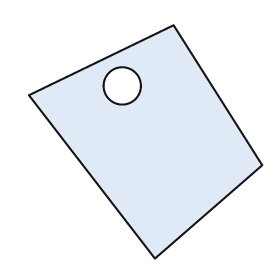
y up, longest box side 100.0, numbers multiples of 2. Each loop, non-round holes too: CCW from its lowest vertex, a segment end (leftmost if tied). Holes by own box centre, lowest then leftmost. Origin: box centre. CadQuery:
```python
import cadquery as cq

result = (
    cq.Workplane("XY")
    .moveTo(4.0, -50.0)
    .lineTo(50.0, -10.0)
    .lineTo(12.0, 50.0)
    .lineTo(-50.0, 20.0)
    .close()
    .moveTo(-10.0, 24.0)
    .circle(8.0)
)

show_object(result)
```